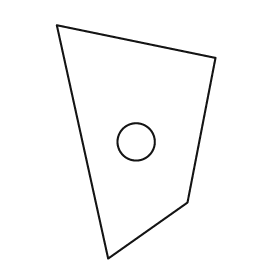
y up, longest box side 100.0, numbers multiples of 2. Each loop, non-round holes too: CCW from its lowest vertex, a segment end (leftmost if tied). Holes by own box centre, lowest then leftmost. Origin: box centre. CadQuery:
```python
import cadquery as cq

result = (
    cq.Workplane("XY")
    .moveTo(-12.0, -50.0)
    .lineTo(22.0, -26.0)
    .lineTo(34.0, 36.0)
    .lineTo(-34.0, 50.0)
    .close()
    .moveTo(0.0, 0.0)
    .circle(8.0)
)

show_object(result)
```